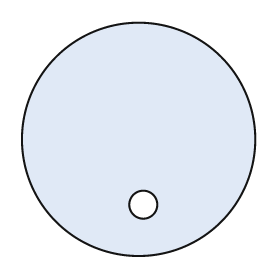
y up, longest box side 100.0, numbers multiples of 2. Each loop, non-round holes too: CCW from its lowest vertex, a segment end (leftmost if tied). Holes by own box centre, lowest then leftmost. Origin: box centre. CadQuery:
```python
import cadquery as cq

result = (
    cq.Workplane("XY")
    .moveTo(0.0, 0.0)
    .circle(50.0)
    .moveTo(2.0, -28.0)
    .circle(6.0)
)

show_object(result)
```